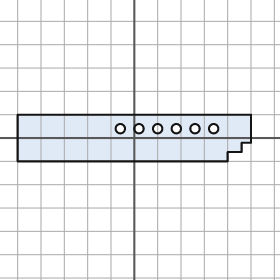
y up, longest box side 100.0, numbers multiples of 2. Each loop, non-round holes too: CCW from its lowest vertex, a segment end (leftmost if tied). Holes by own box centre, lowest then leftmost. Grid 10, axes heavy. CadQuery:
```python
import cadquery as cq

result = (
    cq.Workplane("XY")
    .moveTo(-50.0, -10.0)
    .lineTo(40.0, -10.0)
    .lineTo(40.0, -6.0)
    .lineTo(46.0, -6.0)
    .lineTo(46.0, -2.0)
    .lineTo(50.0, -2.0)
    .lineTo(50.0, 10.0)
    .lineTo(-50.0, 10.0)
    .close()
    .moveTo(-6.0, 4.0)
    .circle(2.0)
    .moveTo(2.0, 4.0)
    .circle(2.0)
    .moveTo(10.0, 4.0)
    .circle(2.0)
    .moveTo(18.0, 4.0)
    .circle(2.0)
    .moveTo(26.0, 4.0)
    .circle(2.0)
    .moveTo(34.0, 4.0)
    .circle(2.0)
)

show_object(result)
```